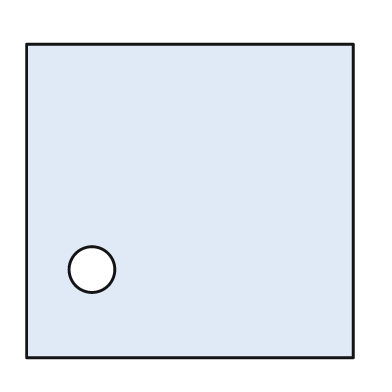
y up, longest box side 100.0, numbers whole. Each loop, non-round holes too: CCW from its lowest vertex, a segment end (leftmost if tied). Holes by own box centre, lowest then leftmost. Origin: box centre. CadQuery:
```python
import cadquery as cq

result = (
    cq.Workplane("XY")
    .moveTo(-50.0, -48.0)
    .lineTo(50.0, -48.0)
    .lineTo(50.0, 48.0)
    .lineTo(-50.0, 48.0)
    .close()
    .moveTo(-30.0, -21.0)
    .circle(7.0)
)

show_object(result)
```